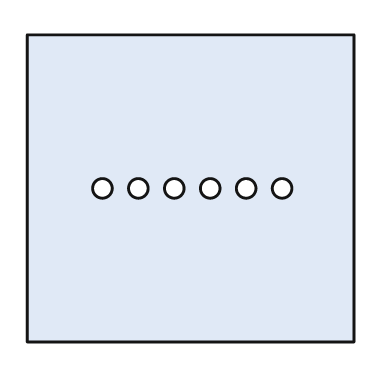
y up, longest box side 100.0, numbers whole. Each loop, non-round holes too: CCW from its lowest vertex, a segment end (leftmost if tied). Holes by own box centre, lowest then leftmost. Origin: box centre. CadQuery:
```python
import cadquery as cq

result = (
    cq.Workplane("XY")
    .moveTo(-50.0, -47.0)
    .lineTo(50.0, -47.0)
    .lineTo(50.0, 47.0)
    .lineTo(-50.0, 47.0)
    .close()
    .moveTo(-27.0, 0.0)
    .circle(3.0)
    .moveTo(-16.0, 0.0)
    .circle(3.0)
    .moveTo(-5.0, 0.0)
    .circle(3.0)
    .moveTo(6.0, 0.0)
    .circle(3.0)
    .moveTo(17.0, 0.0)
    .circle(3.0)
    .moveTo(28.0, 0.0)
    .circle(3.0)
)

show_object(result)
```